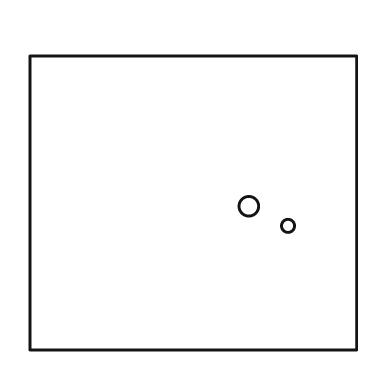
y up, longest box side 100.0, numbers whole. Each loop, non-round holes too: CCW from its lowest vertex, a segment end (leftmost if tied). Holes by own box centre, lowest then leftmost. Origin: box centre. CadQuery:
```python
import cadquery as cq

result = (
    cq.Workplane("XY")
    .moveTo(-50.0, -45.0)
    .lineTo(50.0, -45.0)
    .lineTo(50.0, 45.0)
    .lineTo(-50.0, 45.0)
    .close()
    .moveTo(29.0, -7.0)
    .circle(2.0)
    .moveTo(17.0, -1.0)
    .circle(3.0)
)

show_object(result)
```